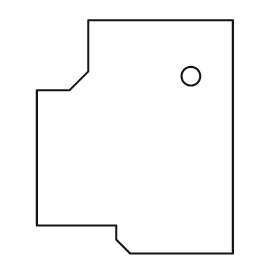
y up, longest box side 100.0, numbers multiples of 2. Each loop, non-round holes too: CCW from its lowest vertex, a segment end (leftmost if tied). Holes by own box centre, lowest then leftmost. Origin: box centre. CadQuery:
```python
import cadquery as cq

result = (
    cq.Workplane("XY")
    .moveTo(-2.0, -50.0)
    .lineTo(42.0, -50.0)
    .lineTo(42.0, 50.0)
    .lineTo(-20.0, 50.0)
    .lineTo(-20.0, 28.0)
    .lineTo(-28.0, 20.0)
    .lineTo(-42.0, 20.0)
    .lineTo(-42.0, -38.0)
    .lineTo(-8.0, -38.0)
    .lineTo(-8.0, -44.0)
    .close()
    .moveTo(24.0, 26.0)
    .circle(4.0)
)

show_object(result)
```